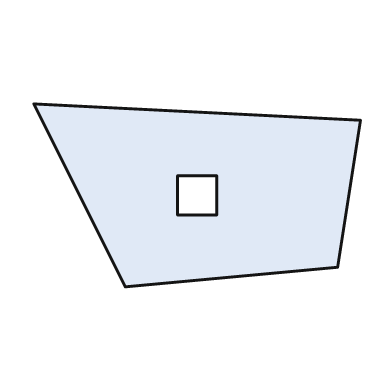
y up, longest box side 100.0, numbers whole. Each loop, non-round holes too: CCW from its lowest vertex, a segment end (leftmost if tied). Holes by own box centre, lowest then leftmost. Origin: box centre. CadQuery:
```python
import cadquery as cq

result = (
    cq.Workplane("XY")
    .moveTo(-22.0, -28.0)
    .lineTo(43.0, -22.0)
    .lineTo(50.0, 23.0)
    .lineTo(-50.0, 28.0)
    .close()
    .moveTo(-6.0, -6.0)
    .lineTo(6.0, -6.0)
    .lineTo(6.0, 6.0)
    .lineTo(-6.0, 6.0)
    .close()
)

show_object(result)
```